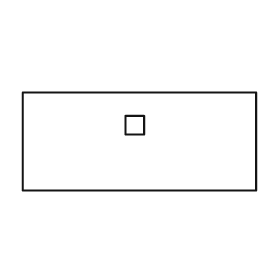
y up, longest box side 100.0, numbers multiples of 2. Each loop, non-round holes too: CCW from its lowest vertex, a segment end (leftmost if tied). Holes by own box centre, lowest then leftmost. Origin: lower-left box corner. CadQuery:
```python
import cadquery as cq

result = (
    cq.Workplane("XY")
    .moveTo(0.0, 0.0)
    .lineTo(100.0, 0.0)
    .lineTo(100.0, 42.0)
    .lineTo(0.0, 42.0)
    .close()
    .moveTo(44.0, 24.0)
    .lineTo(52.0, 24.0)
    .lineTo(52.0, 32.0)
    .lineTo(44.0, 32.0)
    .close()
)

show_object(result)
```